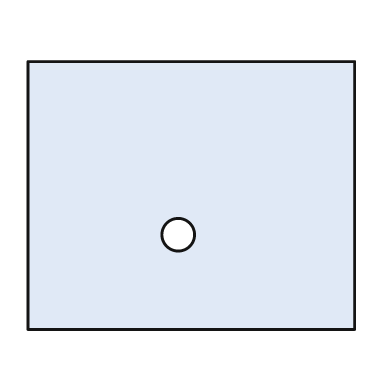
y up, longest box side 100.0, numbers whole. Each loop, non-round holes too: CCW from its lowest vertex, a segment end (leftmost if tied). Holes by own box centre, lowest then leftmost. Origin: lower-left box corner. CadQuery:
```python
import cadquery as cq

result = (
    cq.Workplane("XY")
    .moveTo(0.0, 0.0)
    .lineTo(100.0, 0.0)
    .lineTo(100.0, 82.0)
    .lineTo(0.0, 82.0)
    .close()
    .moveTo(46.0, 29.0)
    .circle(5.0)
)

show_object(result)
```